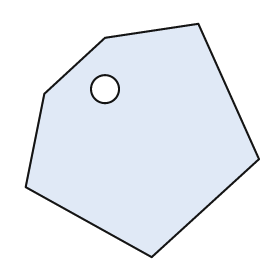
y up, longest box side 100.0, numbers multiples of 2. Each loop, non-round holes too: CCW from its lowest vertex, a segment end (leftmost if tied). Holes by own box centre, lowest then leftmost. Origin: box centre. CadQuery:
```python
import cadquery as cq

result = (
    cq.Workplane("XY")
    .moveTo(4.0, -50.0)
    .lineTo(50.0, -8.0)
    .lineTo(24.0, 50.0)
    .lineTo(-16.0, 44.0)
    .lineTo(-42.0, 20.0)
    .lineTo(-50.0, -20.0)
    .close()
    .moveTo(-16.0, 22.0)
    .circle(6.0)
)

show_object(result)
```